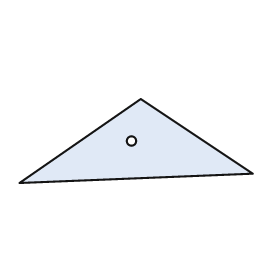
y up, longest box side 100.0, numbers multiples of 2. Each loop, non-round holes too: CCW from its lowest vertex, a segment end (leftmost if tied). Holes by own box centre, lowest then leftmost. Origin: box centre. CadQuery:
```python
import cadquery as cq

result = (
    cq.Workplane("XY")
    .moveTo(-50.0, -18.0)
    .lineTo(50.0, -14.0)
    .lineTo(2.0, 18.0)
    .close()
    .moveTo(-2.0, 0.0)
    .circle(2.0)
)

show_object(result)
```